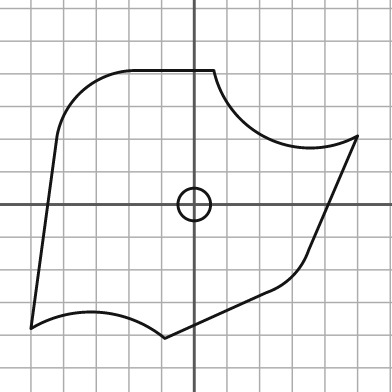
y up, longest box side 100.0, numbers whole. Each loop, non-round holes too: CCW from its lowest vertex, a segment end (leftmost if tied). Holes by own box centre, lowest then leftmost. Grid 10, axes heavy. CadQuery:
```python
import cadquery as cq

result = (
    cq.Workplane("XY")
    .moveTo(-9.0, -41.0)
    .lineTo(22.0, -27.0)
    .threePointArc((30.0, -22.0), (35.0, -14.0))
    .lineTo(50.0, 21.0)
    .threePointArc((23.0, 20.0), (6.0, 41.0))
    .lineTo(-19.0, 41.0)
    .threePointArc((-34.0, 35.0), (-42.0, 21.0))
    .lineTo(-50.0, -38.0)
    .threePointArc((-29.0, -33.0), (-9.0, -41.0))
    .close()
    .moveTo(0.0, 0.0)
    .circle(5.0)
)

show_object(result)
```